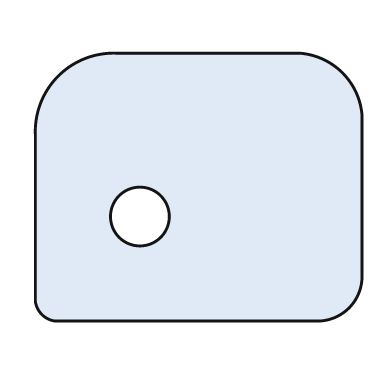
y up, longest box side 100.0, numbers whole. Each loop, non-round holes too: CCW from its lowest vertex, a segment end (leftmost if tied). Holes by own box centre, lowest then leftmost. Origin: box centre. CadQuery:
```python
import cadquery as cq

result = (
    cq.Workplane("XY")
    .moveTo(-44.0, -41.0)
    .lineTo(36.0, -41.0)
    .threePointArc((46.0, -37.0), (50.0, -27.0))
    .lineTo(50.0, 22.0)
    .threePointArc((44.0, 35.0), (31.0, 41.0))
    .lineTo(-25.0, 41.0)
    .threePointArc((-43.0, 34.0), (-50.0, 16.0))
    .lineTo(-50.0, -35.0)
    .threePointArc((-48.0, -39.0), (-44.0, -41.0))
    .close()
    .moveTo(-18.0, -9.0)
    .circle(9.0)
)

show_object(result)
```